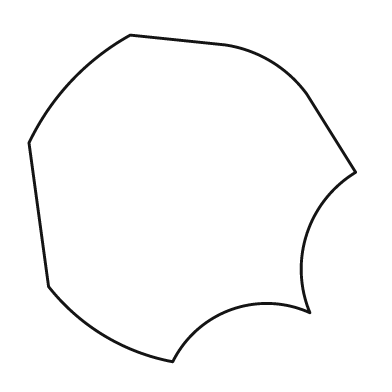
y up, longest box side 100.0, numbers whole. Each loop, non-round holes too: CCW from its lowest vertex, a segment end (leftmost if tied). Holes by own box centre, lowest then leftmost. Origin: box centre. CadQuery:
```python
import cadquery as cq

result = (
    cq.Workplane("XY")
    .moveTo(-6.0, -50.0)
    .threePointArc((12.0, -34.0), (36.0, -35.0))
    .threePointArc((35.0, -11.0), (50.0, 8.0))
    .lineTo(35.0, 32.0)
    .threePointArc((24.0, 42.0), (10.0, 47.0))
    .lineTo(-19.0, 50.0)
    .threePointArc((-37.0, 36.0), (-50.0, 17.0))
    .lineTo(-44.0, -27.0)
    .threePointArc((-27.0, -42.0), (-6.0, -50.0))
    .close()
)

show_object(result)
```